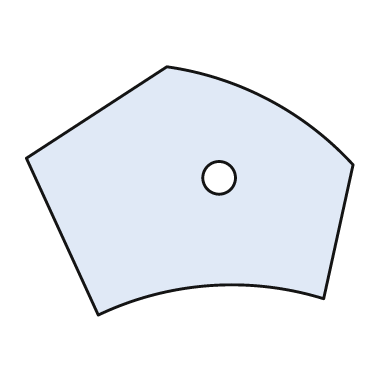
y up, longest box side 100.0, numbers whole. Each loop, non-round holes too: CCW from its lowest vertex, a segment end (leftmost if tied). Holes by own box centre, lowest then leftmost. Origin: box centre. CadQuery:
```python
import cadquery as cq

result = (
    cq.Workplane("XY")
    .moveTo(-28.0, -38.0)
    .threePointArc((6.0, -29.0), (41.0, -33.0))
    .lineTo(50.0, 8.0)
    .threePointArc((24.0, 28.0), (-7.0, 38.0))
    .lineTo(-50.0, 10.0)
    .close()
    .moveTo(9.0, 4.0)
    .circle(5.0)
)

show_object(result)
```